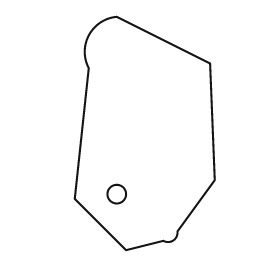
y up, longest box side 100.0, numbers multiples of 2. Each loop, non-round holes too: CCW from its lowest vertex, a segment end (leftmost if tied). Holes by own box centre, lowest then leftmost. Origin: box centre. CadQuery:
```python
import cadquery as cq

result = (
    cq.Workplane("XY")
    .moveTo(-8.0, -50.0)
    .lineTo(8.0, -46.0)
    .threePointArc((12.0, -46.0), (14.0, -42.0))
    .lineTo(30.0, -20.0)
    .lineTo(28.0, 30.0)
    .lineTo(-12.0, 50.0)
    .threePointArc((-24.0, 42.0), (-24.0, 28.0))
    .lineTo(-30.0, -28.0)
    .close()
    .moveTo(-12.0, -26.0)
    .circle(4.0)
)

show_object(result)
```